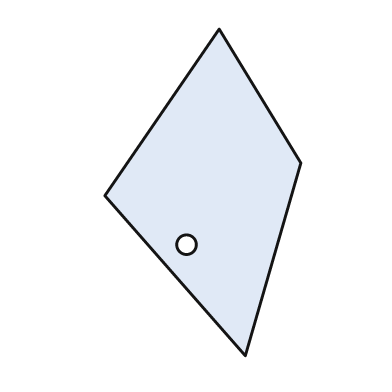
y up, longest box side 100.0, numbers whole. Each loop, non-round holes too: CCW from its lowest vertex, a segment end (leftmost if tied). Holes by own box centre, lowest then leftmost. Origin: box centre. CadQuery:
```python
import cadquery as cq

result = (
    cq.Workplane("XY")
    .moveTo(13.0, -50.0)
    .lineTo(30.0, 9.0)
    .lineTo(5.0, 50.0)
    .lineTo(-30.0, -1.0)
    .close()
    .moveTo(-5.0, -16.0)
    .circle(3.0)
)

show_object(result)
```